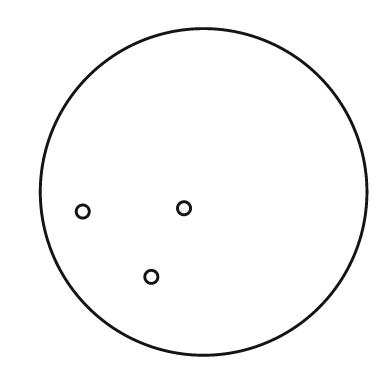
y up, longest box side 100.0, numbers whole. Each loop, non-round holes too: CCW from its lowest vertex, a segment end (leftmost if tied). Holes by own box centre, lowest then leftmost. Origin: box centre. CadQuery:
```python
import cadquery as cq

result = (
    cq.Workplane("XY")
    .moveTo(0.0, 0.0)
    .circle(50.0)
    .moveTo(-16.0, -26.0)
    .circle(2.0)
    .moveTo(-37.0, -6.0)
    .circle(2.0)
    .moveTo(-6.0, -5.0)
    .circle(2.0)
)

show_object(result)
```